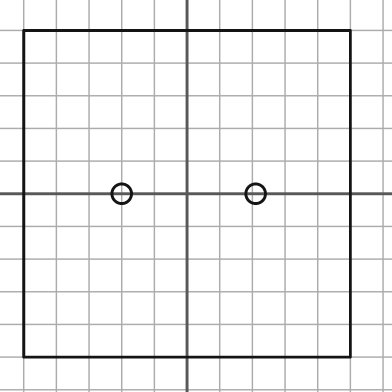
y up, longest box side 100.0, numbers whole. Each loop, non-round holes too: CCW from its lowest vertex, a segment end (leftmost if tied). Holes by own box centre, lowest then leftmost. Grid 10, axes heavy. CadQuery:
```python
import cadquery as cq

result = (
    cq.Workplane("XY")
    .moveTo(-50.0, -50.0)
    .lineTo(50.0, -50.0)
    .lineTo(50.0, 50.0)
    .lineTo(-50.0, 50.0)
    .close()
    .moveTo(-20.0, 0.0)
    .circle(3.0)
    .moveTo(21.0, 0.0)
    .circle(3.0)
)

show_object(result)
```